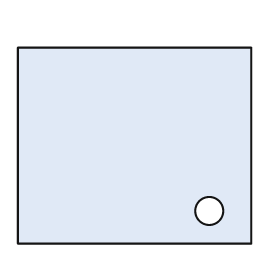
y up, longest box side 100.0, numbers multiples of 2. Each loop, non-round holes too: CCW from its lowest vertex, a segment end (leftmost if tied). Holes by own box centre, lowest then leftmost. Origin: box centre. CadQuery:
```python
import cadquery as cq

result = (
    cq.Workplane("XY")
    .moveTo(-50.0, -42.0)
    .lineTo(50.0, -42.0)
    .lineTo(50.0, 42.0)
    .lineTo(-50.0, 42.0)
    .close()
    .moveTo(32.0, -28.0)
    .circle(6.0)
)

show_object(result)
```